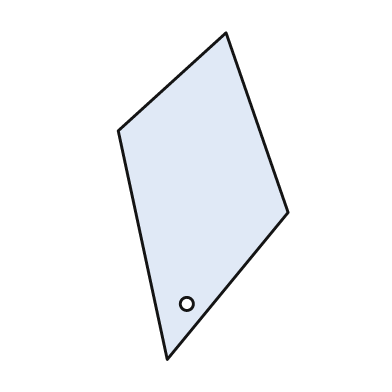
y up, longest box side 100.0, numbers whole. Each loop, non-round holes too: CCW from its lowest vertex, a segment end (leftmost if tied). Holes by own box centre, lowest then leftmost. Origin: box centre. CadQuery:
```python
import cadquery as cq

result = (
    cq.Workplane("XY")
    .moveTo(-11.0, -50.0)
    .lineTo(26.0, -5.0)
    .lineTo(7.0, 50.0)
    .lineTo(-26.0, 20.0)
    .close()
    .moveTo(-5.0, -33.0)
    .circle(2.0)
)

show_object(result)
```